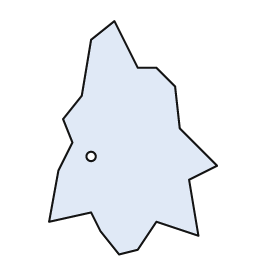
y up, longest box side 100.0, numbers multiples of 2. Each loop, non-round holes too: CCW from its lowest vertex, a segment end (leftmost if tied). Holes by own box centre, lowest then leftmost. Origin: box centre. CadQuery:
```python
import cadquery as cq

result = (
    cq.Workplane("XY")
    .moveTo(-6.0, -50.0)
    .lineTo(2.0, -48.0)
    .lineTo(10.0, -36.0)
    .lineTo(28.0, -42.0)
    .lineTo(24.0, -18.0)
    .lineTo(36.0, -12.0)
    .lineTo(20.0, 4.0)
    .lineTo(18.0, 22.0)
    .lineTo(10.0, 30.0)
    .lineTo(2.0, 30.0)
    .lineTo(-8.0, 50.0)
    .lineTo(-18.0, 42.0)
    .lineTo(-22.0, 18.0)
    .lineTo(-30.0, 8.0)
    .lineTo(-26.0, -2.0)
    .lineTo(-32.0, -14.0)
    .lineTo(-36.0, -36.0)
    .lineTo(-18.0, -32.0)
    .lineTo(-14.0, -40.0)
    .close()
    .moveTo(-18.0, -8.0)
    .circle(2.0)
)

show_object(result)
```